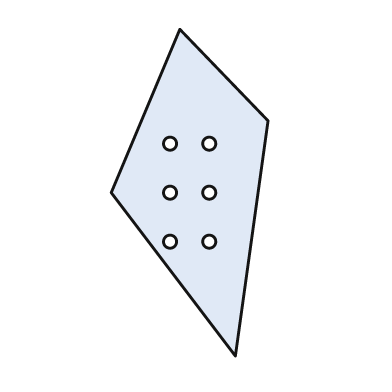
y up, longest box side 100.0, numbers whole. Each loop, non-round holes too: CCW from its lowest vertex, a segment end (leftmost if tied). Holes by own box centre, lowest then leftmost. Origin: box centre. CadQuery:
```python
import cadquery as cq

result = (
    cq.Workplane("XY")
    .moveTo(14.0, -50.0)
    .lineTo(24.0, 22.0)
    .lineTo(-3.0, 50.0)
    .lineTo(-24.0, 0.0)
    .close()
    .moveTo(-6.0, -15.0)
    .circle(2.0)
    .moveTo(6.0, -15.0)
    .circle(2.0)
    .moveTo(-6.0, 0.0)
    .circle(2.0)
    .moveTo(6.0, 0.0)
    .circle(2.0)
    .moveTo(-6.0, 15.0)
    .circle(2.0)
    .moveTo(6.0, 15.0)
    .circle(2.0)
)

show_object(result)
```